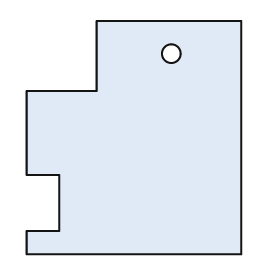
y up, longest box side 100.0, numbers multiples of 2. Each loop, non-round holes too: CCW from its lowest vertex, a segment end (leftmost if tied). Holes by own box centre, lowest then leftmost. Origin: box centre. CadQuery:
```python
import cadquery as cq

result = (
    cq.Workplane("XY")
    .moveTo(-46.0, -50.0)
    .lineTo(46.0, -50.0)
    .lineTo(46.0, 50.0)
    .lineTo(-16.0, 50.0)
    .lineTo(-16.0, 20.0)
    .lineTo(-46.0, 20.0)
    .lineTo(-46.0, -16.0)
    .lineTo(-32.0, -16.0)
    .lineTo(-32.0, -40.0)
    .lineTo(-46.0, -40.0)
    .close()
    .moveTo(16.0, 36.0)
    .circle(4.0)
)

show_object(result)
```